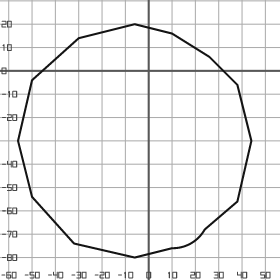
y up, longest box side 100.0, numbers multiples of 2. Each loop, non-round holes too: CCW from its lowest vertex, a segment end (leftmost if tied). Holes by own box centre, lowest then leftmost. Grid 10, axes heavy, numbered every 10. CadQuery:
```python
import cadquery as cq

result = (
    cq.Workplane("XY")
    .moveTo(-6.0, -80.0)
    .lineTo(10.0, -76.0)
    .threePointArc((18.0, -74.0), (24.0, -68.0))
    .lineTo(38.0, -56.0)
    .lineTo(44.0, -30.0)
    .lineTo(38.0, -6.0)
    .lineTo(26.0, 6.0)
    .lineTo(10.0, 16.0)
    .lineTo(-6.0, 20.0)
    .lineTo(-30.0, 14.0)
    .lineTo(-50.0, -4.0)
    .lineTo(-56.0, -30.0)
    .lineTo(-50.0, -54.0)
    .lineTo(-32.0, -74.0)
    .close()
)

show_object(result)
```